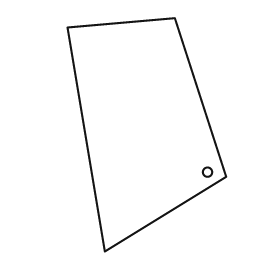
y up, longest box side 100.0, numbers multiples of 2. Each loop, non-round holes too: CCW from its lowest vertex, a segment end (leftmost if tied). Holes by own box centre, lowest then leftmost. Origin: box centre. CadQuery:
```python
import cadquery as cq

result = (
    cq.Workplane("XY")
    .moveTo(-18.0, -50.0)
    .lineTo(34.0, -18.0)
    .lineTo(12.0, 50.0)
    .lineTo(-34.0, 46.0)
    .close()
    .moveTo(26.0, -16.0)
    .circle(2.0)
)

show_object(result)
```